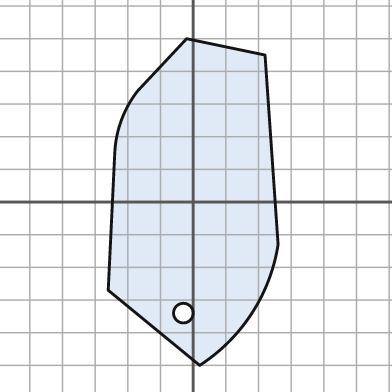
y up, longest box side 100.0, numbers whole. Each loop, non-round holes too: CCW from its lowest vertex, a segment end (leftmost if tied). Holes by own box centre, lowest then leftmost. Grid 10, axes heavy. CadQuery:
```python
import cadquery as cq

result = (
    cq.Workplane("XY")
    .moveTo(2.0, -50.0)
    .threePointArc((18.0, -34.0), (26.0, -13.0))
    .lineTo(22.0, 45.0)
    .lineTo(-2.0, 50.0)
    .lineTo(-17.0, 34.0)
    .threePointArc((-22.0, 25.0), (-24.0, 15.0))
    .lineTo(-26.0, -27.0)
    .close()
    .moveTo(-3.0, -34.0)
    .circle(3.0)
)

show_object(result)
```